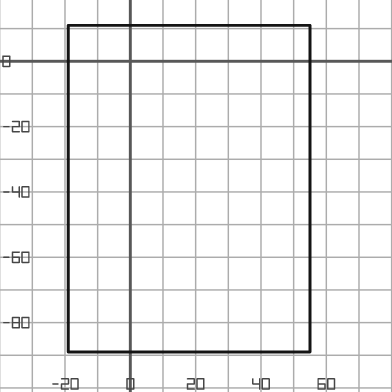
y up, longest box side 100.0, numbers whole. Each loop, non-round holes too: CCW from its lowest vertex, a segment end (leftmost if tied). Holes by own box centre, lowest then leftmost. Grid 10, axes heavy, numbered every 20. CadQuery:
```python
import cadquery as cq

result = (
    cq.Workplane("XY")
    .moveTo(-19.0, -89.0)
    .lineTo(55.0, -89.0)
    .lineTo(55.0, 11.0)
    .lineTo(-19.0, 11.0)
    .close()
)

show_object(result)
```